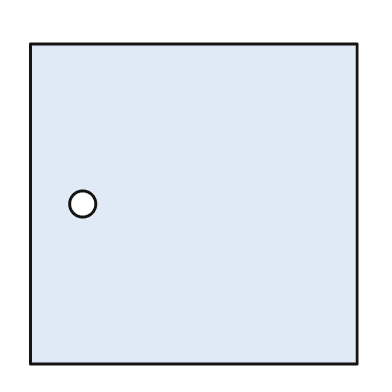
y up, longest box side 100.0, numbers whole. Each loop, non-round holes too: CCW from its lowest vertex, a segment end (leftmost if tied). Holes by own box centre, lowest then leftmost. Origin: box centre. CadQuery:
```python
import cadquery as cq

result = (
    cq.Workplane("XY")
    .moveTo(-50.0, -49.0)
    .lineTo(50.0, -49.0)
    .lineTo(50.0, 49.0)
    .lineTo(-50.0, 49.0)
    .close()
    .moveTo(-34.0, 0.0)
    .circle(4.0)
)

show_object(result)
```